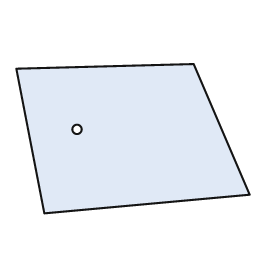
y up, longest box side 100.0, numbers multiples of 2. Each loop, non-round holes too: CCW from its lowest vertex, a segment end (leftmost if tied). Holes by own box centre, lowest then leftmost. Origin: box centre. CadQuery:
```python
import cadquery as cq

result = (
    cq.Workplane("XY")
    .moveTo(-38.0, -32.0)
    .lineTo(50.0, -24.0)
    .lineTo(26.0, 32.0)
    .lineTo(-50.0, 30.0)
    .close()
    .moveTo(-24.0, 4.0)
    .circle(2.0)
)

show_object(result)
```